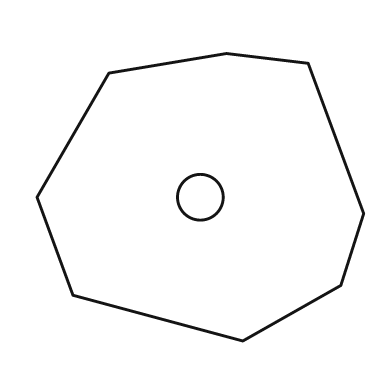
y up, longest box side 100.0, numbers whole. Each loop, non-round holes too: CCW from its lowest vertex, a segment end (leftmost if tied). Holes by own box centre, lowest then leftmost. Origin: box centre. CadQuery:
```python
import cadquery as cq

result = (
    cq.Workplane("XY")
    .moveTo(13.0, -44.0)
    .lineTo(43.0, -27.0)
    .lineTo(50.0, -5.0)
    .lineTo(33.0, 41.0)
    .lineTo(8.0, 44.0)
    .lineTo(-28.0, 38.0)
    .lineTo(-50.0, 0.0)
    .lineTo(-39.0, -30.0)
    .close()
    .moveTo(0.0, 0.0)
    .circle(7.0)
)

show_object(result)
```